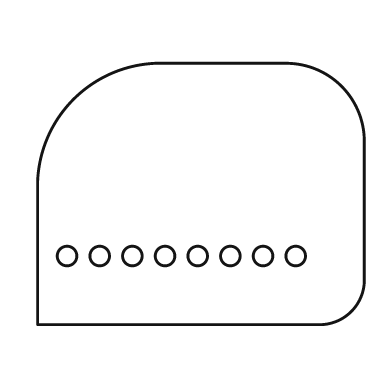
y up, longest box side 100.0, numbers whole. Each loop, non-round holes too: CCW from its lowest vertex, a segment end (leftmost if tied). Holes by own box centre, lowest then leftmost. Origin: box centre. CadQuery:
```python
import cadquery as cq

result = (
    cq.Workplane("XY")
    .moveTo(-50.0, -40.0)
    .lineTo(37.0, -40.0)
    .threePointArc((46.0, -36.0), (50.0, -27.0))
    .lineTo(50.0, 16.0)
    .threePointArc((43.0, 33.0), (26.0, 40.0))
    .lineTo(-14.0, 40.0)
    .threePointArc((-39.0, 29.0), (-50.0, 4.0))
    .close()
    .moveTo(-41.0, -19.0)
    .circle(3.0)
    .moveTo(-31.0, -19.0)
    .circle(3.0)
    .moveTo(-21.0, -19.0)
    .circle(3.0)
    .moveTo(-11.0, -19.0)
    .circle(3.0)
    .moveTo(-1.0, -19.0)
    .circle(3.0)
    .moveTo(9.0, -19.0)
    .circle(3.0)
    .moveTo(19.0, -19.0)
    .circle(3.0)
    .moveTo(29.0, -19.0)
    .circle(3.0)
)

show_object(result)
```